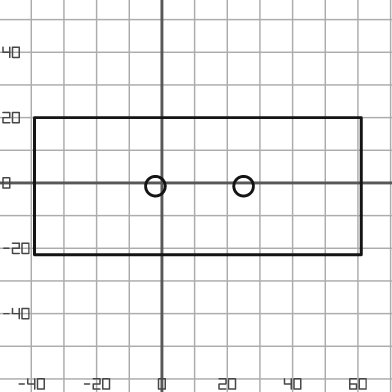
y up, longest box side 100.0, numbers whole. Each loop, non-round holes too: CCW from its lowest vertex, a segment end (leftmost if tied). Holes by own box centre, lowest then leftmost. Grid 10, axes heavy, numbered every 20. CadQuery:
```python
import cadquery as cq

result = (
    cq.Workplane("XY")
    .moveTo(-39.0, -22.0)
    .lineTo(61.0, -22.0)
    .lineTo(61.0, 20.0)
    .lineTo(-39.0, 20.0)
    .close()
    .moveTo(-2.0, -1.0)
    .circle(3.0)
    .moveTo(25.0, -1.0)
    .circle(3.0)
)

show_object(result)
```